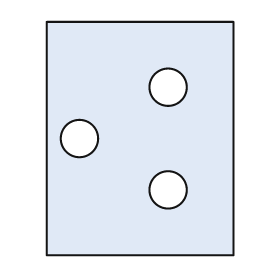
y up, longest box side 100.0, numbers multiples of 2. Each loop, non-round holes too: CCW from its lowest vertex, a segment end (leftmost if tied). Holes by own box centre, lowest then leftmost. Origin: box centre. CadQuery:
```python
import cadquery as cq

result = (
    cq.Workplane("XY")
    .moveTo(-40.0, -50.0)
    .lineTo(40.0, -50.0)
    .lineTo(40.0, 50.0)
    .lineTo(-40.0, 50.0)
    .close()
    .moveTo(12.0, -22.0)
    .circle(8.0)
    .moveTo(-26.0, 0.0)
    .circle(8.0)
    .moveTo(12.0, 22.0)
    .circle(8.0)
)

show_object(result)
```